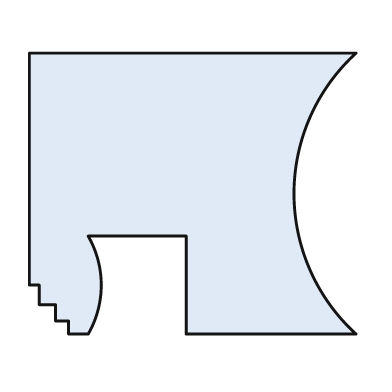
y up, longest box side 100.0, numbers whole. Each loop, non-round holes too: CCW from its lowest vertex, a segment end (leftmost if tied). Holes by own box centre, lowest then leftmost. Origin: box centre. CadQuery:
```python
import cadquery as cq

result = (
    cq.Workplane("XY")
    .moveTo(-38.0, -43.0)
    .lineTo(-32.0, -43.0)
    .threePointArc((-28.0, -28.0), (-32.0, -13.0))
    .lineTo(-2.0, -13.0)
    .lineTo(-2.0, -43.0)
    .lineTo(50.0, -43.0)
    .threePointArc((31.0, 0.0), (50.0, 43.0))
    .lineTo(-50.0, 43.0)
    .lineTo(-50.0, -28.0)
    .lineTo(-47.0, -28.0)
    .lineTo(-47.0, -34.0)
    .lineTo(-42.0, -34.0)
    .lineTo(-42.0, -39.0)
    .lineTo(-38.0, -39.0)
    .close()
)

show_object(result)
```